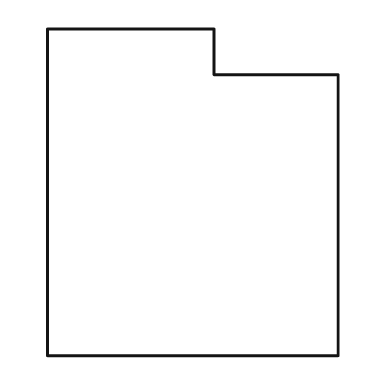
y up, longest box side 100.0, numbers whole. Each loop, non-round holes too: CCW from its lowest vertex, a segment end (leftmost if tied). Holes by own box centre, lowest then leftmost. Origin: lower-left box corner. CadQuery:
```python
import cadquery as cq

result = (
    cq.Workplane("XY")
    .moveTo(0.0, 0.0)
    .lineTo(89.0, 0.0)
    .lineTo(89.0, 86.0)
    .lineTo(51.0, 86.0)
    .lineTo(51.0, 100.0)
    .lineTo(0.0, 100.0)
    .close()
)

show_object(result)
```